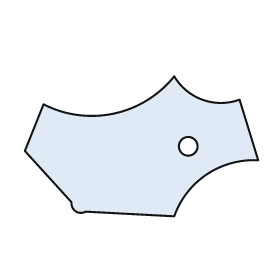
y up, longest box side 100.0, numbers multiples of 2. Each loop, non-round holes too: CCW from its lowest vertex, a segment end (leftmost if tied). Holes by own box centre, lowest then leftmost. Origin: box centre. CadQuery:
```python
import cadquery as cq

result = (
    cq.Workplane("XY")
    .moveTo(14.0, -30.0)
    .threePointArc((28.0, -12.0), (50.0, -6.0))
    .lineTo(42.0, 20.0)
    .threePointArc((26.0, 20.0), (14.0, 30.0))
    .threePointArc((-12.0, 14.0), (-42.0, 18.0))
    .lineTo(-50.0, -2.0)
    .lineTo(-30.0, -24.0)
    .threePointArc((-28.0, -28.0), (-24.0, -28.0))
    .close()
    .moveTo(20.0, 0.0)
    .circle(4.0)
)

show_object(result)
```